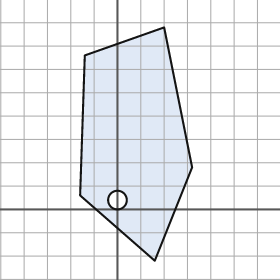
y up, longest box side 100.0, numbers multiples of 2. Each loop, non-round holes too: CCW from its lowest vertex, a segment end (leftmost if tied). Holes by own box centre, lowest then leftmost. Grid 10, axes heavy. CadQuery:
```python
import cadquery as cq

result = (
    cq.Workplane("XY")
    .moveTo(16.0, -22.0)
    .lineTo(32.0, 18.0)
    .lineTo(20.0, 78.0)
    .lineTo(-14.0, 66.0)
    .lineTo(-16.0, 6.0)
    .close()
    .moveTo(0.0, 4.0)
    .circle(4.0)
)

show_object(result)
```